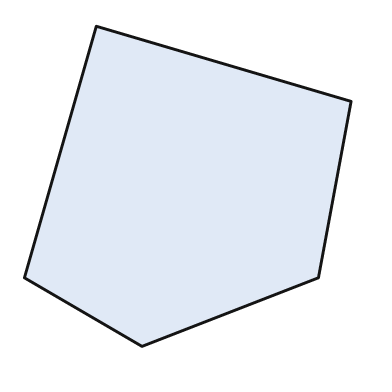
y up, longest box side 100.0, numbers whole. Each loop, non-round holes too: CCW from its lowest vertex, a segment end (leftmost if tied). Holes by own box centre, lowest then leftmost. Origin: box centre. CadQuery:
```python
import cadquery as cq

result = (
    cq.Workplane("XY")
    .moveTo(-14.0, -49.0)
    .lineTo(40.0, -28.0)
    .lineTo(50.0, 26.0)
    .lineTo(-28.0, 49.0)
    .lineTo(-50.0, -28.0)
    .close()
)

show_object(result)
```